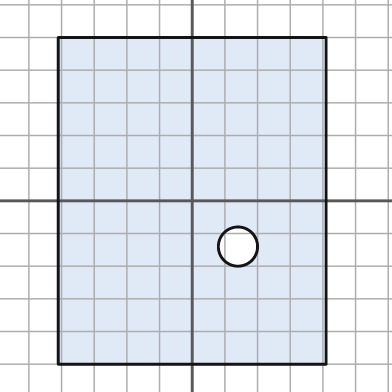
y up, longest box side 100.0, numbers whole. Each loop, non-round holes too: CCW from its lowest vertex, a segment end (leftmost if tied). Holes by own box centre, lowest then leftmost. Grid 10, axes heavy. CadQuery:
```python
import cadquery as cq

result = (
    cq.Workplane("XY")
    .moveTo(-41.0, -50.0)
    .lineTo(41.0, -50.0)
    .lineTo(41.0, 50.0)
    .lineTo(-41.0, 50.0)
    .close()
    .moveTo(14.0, -14.0)
    .circle(6.0)
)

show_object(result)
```